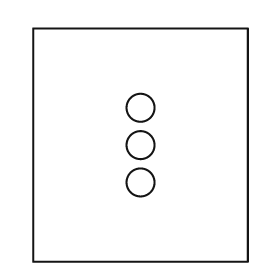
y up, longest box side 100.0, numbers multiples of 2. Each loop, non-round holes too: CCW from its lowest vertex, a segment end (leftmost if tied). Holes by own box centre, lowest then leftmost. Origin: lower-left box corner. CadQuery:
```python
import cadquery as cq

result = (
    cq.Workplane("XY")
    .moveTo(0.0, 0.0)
    .lineTo(92.0, 0.0)
    .lineTo(92.0, 100.0)
    .lineTo(0.0, 100.0)
    .close()
    .moveTo(46.0, 34.0)
    .circle(6.0)
    .moveTo(46.0, 50.0)
    .circle(6.0)
    .moveTo(46.0, 66.0)
    .circle(6.0)
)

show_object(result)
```